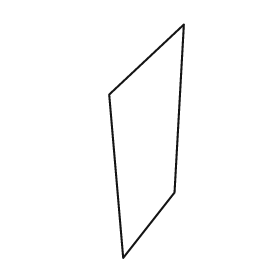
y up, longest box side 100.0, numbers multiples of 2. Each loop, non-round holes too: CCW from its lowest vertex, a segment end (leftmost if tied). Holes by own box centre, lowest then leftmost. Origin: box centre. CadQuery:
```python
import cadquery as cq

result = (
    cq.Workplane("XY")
    .moveTo(-10.0, -50.0)
    .lineTo(12.0, -22.0)
    .lineTo(16.0, 50.0)
    .lineTo(-16.0, 20.0)
    .close()
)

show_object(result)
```